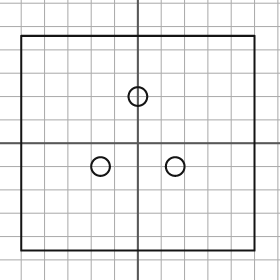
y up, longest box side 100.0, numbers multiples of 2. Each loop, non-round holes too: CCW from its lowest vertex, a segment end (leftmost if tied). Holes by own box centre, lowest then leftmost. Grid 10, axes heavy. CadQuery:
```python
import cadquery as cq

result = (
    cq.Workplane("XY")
    .moveTo(-50.0, -46.0)
    .lineTo(50.0, -46.0)
    .lineTo(50.0, 46.0)
    .lineTo(-50.0, 46.0)
    .close()
    .moveTo(-16.0, -10.0)
    .circle(4.0)
    .moveTo(16.0, -10.0)
    .circle(4.0)
    .moveTo(0.0, 20.0)
    .circle(4.0)
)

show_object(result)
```